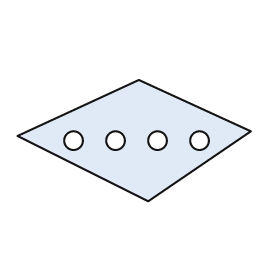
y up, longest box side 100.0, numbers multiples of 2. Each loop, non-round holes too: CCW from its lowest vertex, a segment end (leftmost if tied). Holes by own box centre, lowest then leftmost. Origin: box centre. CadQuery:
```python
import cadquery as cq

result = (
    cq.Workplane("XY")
    .moveTo(6.0, -26.0)
    .lineTo(50.0, 4.0)
    .lineTo(2.0, 26.0)
    .lineTo(-50.0, 2.0)
    .close()
    .moveTo(-26.0, 0.0)
    .circle(4.0)
    .moveTo(-8.0, 0.0)
    .circle(4.0)
    .moveTo(10.0, 0.0)
    .circle(4.0)
    .moveTo(28.0, 0.0)
    .circle(4.0)
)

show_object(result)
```